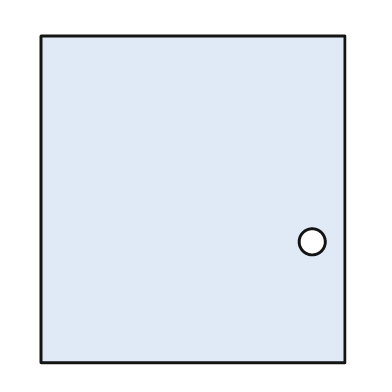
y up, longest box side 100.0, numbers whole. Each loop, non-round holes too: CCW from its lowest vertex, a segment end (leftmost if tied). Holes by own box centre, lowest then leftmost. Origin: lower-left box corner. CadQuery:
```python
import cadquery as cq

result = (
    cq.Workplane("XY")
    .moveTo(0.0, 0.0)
    .lineTo(93.0, 0.0)
    .lineTo(93.0, 100.0)
    .lineTo(0.0, 100.0)
    .close()
    .moveTo(83.0, 37.0)
    .circle(4.0)
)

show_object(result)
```